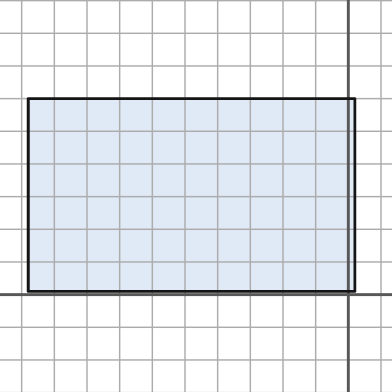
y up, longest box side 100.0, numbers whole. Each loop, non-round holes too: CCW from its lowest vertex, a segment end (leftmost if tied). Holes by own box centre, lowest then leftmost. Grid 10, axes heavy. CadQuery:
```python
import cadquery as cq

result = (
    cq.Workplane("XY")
    .moveTo(-98.0, 1.0)
    .lineTo(2.0, 1.0)
    .lineTo(2.0, 60.0)
    .lineTo(-98.0, 60.0)
    .close()
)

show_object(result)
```